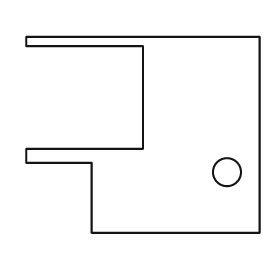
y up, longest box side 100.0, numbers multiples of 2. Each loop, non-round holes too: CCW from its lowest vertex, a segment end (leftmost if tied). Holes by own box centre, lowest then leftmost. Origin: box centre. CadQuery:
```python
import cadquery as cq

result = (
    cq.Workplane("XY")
    .moveTo(-22.0, -42.0)
    .lineTo(50.0, -42.0)
    .lineTo(50.0, 42.0)
    .lineTo(-50.0, 42.0)
    .lineTo(-50.0, 38.0)
    .lineTo(0.0, 38.0)
    .lineTo(0.0, -6.0)
    .lineTo(-50.0, -6.0)
    .lineTo(-50.0, -12.0)
    .lineTo(-22.0, -12.0)
    .close()
    .moveTo(36.0, -16.0)
    .circle(6.0)
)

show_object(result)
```